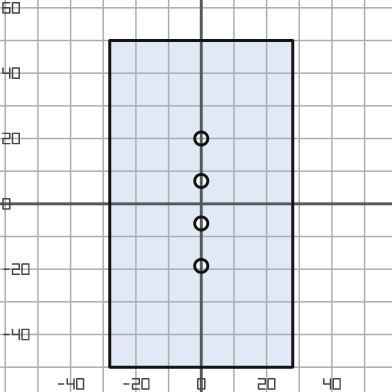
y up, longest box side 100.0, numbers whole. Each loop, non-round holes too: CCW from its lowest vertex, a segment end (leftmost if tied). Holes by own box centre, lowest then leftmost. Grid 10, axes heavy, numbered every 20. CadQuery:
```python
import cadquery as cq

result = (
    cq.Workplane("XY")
    .moveTo(-28.0, -50.0)
    .lineTo(28.0, -50.0)
    .lineTo(28.0, 50.0)
    .lineTo(-28.0, 50.0)
    .close()
    .moveTo(0.0, -19.0)
    .circle(2.0)
    .moveTo(0.0, -6.0)
    .circle(2.0)
    .moveTo(0.0, 7.0)
    .circle(2.0)
    .moveTo(0.0, 20.0)
    .circle(2.0)
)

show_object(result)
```